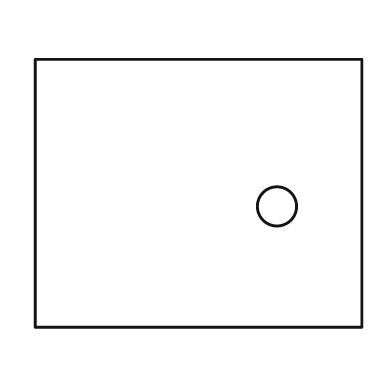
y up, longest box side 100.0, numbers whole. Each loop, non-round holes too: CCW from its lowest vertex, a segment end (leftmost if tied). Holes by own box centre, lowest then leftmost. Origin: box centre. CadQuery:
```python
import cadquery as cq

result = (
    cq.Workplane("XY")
    .moveTo(-50.0, -41.0)
    .lineTo(50.0, -41.0)
    .lineTo(50.0, 41.0)
    .lineTo(-50.0, 41.0)
    .close()
    .moveTo(24.0, -4.0)
    .circle(6.0)
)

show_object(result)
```